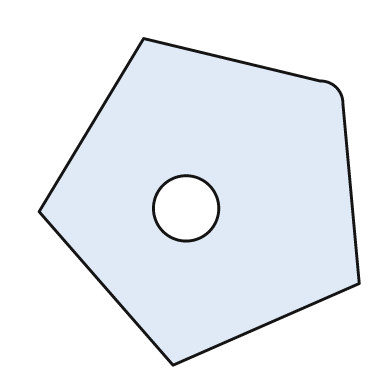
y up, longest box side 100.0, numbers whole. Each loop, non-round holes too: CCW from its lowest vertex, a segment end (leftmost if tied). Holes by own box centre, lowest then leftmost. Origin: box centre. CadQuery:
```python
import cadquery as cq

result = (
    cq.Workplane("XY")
    .moveTo(-8.0, -50.0)
    .lineTo(49.0, -25.0)
    .lineTo(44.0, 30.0)
    .threePointArc((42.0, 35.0), (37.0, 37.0))
    .lineTo(-17.0, 50.0)
    .lineTo(-49.0, -3.0)
    .close()
    .moveTo(-4.0, -2.0)
    .circle(10.0)
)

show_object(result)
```